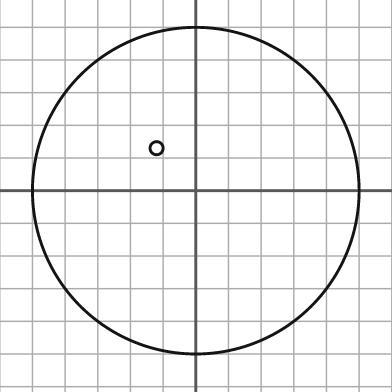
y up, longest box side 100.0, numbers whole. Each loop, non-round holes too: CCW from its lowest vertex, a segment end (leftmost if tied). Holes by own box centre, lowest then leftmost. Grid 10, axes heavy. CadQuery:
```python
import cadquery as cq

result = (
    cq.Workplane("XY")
    .moveTo(0.0, 0.0)
    .circle(50.0)
    .moveTo(-12.0, 13.0)
    .circle(2.0)
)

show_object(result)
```